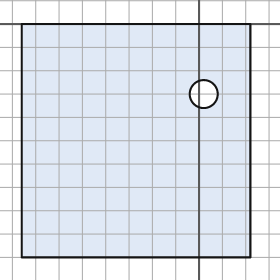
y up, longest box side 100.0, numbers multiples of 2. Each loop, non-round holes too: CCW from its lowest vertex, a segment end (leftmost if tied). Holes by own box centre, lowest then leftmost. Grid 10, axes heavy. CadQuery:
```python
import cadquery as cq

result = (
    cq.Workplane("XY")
    .moveTo(-76.0, -100.0)
    .lineTo(22.0, -100.0)
    .lineTo(22.0, 0.0)
    .lineTo(-76.0, 0.0)
    .close()
    .moveTo(2.0, -30.0)
    .circle(6.0)
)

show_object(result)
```